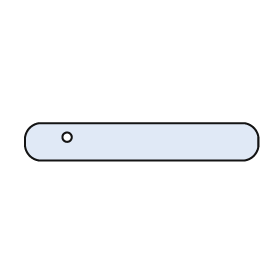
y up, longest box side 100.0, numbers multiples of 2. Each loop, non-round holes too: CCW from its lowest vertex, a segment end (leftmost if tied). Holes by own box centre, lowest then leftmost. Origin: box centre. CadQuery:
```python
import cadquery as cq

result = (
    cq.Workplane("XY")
    .moveTo(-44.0, -8.0)
    .lineTo(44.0, -8.0)
    .threePointArc((48.0, -6.0), (50.0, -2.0))
    .lineTo(50.0, 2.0)
    .threePointArc((48.0, 6.0), (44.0, 8.0))
    .lineTo(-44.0, 8.0)
    .threePointArc((-48.0, 6.0), (-50.0, 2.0))
    .lineTo(-50.0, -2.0)
    .threePointArc((-48.0, -6.0), (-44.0, -8.0))
    .close()
    .moveTo(-32.0, 2.0)
    .circle(2.0)
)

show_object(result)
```